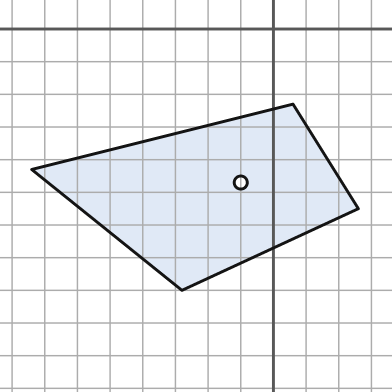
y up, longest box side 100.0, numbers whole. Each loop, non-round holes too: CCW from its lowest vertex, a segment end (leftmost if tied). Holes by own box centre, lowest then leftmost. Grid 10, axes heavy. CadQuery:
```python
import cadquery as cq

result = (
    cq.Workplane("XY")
    .moveTo(-28.0, -80.0)
    .lineTo(26.0, -55.0)
    .lineTo(6.0, -23.0)
    .lineTo(-74.0, -43.0)
    .close()
    .moveTo(-10.0, -47.0)
    .circle(2.0)
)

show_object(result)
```